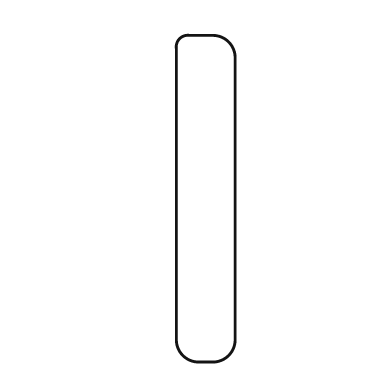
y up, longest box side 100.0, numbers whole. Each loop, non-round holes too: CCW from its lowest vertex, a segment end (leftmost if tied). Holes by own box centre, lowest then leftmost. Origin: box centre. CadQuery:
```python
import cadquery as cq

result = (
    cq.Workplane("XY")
    .moveTo(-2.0, -50.0)
    .lineTo(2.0, -50.0)
    .threePointArc((7.0, -48.0), (9.0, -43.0))
    .lineTo(9.0, 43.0)
    .threePointArc((7.0, 48.0), (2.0, 50.0))
    .lineTo(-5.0, 50.0)
    .threePointArc((-8.0, 49.0), (-9.0, 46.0))
    .lineTo(-9.0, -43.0)
    .threePointArc((-7.0, -48.0), (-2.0, -50.0))
    .close()
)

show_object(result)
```